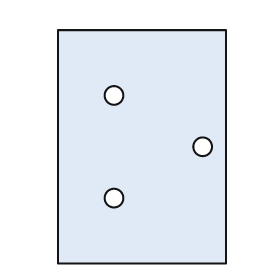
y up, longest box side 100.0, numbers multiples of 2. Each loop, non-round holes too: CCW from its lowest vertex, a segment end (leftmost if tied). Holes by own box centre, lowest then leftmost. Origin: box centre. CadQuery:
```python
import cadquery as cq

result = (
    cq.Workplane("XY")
    .moveTo(-36.0, -50.0)
    .lineTo(36.0, -50.0)
    .lineTo(36.0, 50.0)
    .lineTo(-36.0, 50.0)
    .close()
    .moveTo(-12.0, -22.0)
    .circle(4.0)
    .moveTo(26.0, 0.0)
    .circle(4.0)
    .moveTo(-12.0, 22.0)
    .circle(4.0)
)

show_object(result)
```